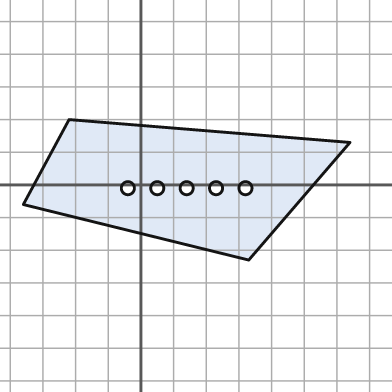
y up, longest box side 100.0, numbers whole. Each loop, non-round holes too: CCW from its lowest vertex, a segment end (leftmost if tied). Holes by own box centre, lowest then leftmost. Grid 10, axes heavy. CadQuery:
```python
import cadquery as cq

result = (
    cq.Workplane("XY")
    .moveTo(33.0, -23.0)
    .lineTo(64.0, 13.0)
    .lineTo(-22.0, 20.0)
    .lineTo(-36.0, -6.0)
    .close()
    .moveTo(-4.0, -1.0)
    .circle(2.0)
    .moveTo(5.0, -1.0)
    .circle(2.0)
    .moveTo(14.0, -1.0)
    .circle(2.0)
    .moveTo(23.0, -1.0)
    .circle(2.0)
    .moveTo(32.0, -1.0)
    .circle(2.0)
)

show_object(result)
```